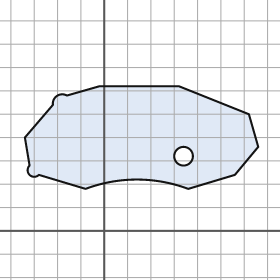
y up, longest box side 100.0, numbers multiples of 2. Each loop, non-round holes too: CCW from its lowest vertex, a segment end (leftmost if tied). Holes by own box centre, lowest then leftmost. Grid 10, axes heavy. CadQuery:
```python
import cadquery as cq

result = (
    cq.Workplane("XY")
    .moveTo(-8.0, 18.0)
    .threePointArc((14.0, 22.0), (36.0, 18.0))
    .lineTo(56.0, 24.0)
    .lineTo(66.0, 36.0)
    .lineTo(62.0, 50.0)
    .lineTo(32.0, 62.0)
    .lineTo(-2.0, 62.0)
    .lineTo(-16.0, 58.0)
    .threePointArc((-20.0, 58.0), (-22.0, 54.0))
    .lineTo(-34.0, 40.0)
    .lineTo(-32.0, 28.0)
    .threePointArc((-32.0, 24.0), (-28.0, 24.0))
    .close()
    .moveTo(34.0, 32.0)
    .circle(4.0)
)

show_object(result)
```